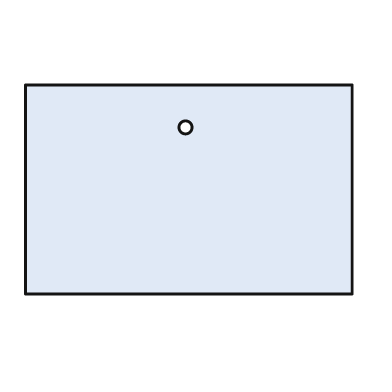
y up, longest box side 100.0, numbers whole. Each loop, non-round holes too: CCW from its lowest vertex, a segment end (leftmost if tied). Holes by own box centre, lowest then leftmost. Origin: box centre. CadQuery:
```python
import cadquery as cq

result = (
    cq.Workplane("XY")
    .moveTo(-50.0, -32.0)
    .lineTo(50.0, -32.0)
    .lineTo(50.0, 32.0)
    .lineTo(-50.0, 32.0)
    .close()
    .moveTo(-1.0, 19.0)
    .circle(2.0)
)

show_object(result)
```